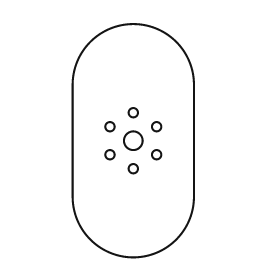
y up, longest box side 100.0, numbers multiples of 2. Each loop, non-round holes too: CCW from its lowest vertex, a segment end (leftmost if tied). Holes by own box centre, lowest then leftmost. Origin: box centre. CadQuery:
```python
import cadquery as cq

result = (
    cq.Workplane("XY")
    .moveTo(-26.0, -24.0)
    .threePointArc((0.0, -50.0), (26.0, -24.0))
    .lineTo(26.0, 24.0)
    .threePointArc((0.0, 50.0), (-26.0, 24.0))
    .close()
    .moveTo(0.0, -12.0)
    .circle(2.0)
    .moveTo(-10.0, -6.0)
    .circle(2.0)
    .moveTo(10.0, -6.0)
    .circle(2.0)
    .moveTo(0.0, 0.0)
    .circle(4.0)
    .moveTo(-10.0, 6.0)
    .circle(2.0)
    .moveTo(10.0, 6.0)
    .circle(2.0)
    .moveTo(0.0, 12.0)
    .circle(2.0)
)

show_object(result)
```